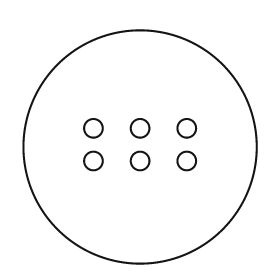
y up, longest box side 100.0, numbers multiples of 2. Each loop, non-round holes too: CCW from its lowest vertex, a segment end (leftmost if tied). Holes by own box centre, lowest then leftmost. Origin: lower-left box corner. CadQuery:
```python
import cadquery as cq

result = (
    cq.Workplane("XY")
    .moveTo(50.0, 50.0)
    .circle(50.0)
    .moveTo(30.0, 44.0)
    .circle(4.0)
    .moveTo(50.0, 44.0)
    .circle(4.0)
    .moveTo(70.0, 44.0)
    .circle(4.0)
    .moveTo(30.0, 58.0)
    .circle(4.0)
    .moveTo(50.0, 58.0)
    .circle(4.0)
    .moveTo(70.0, 58.0)
    .circle(4.0)
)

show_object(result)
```